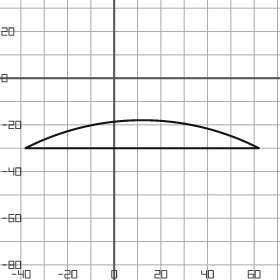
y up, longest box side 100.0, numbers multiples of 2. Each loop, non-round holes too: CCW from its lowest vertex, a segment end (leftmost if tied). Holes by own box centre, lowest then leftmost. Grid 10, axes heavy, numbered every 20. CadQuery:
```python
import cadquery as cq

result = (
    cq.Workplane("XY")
    .moveTo(-38.0, -30.0)
    .lineTo(62.0, -30.0)
    .threePointArc((12.0, -18.0), (-38.0, -30.0))
    .close()
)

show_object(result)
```